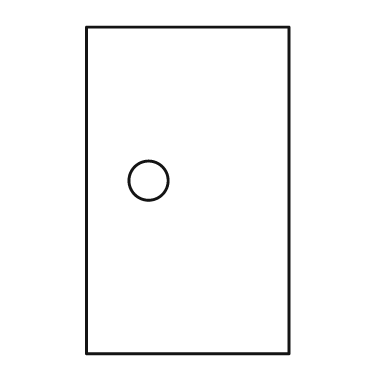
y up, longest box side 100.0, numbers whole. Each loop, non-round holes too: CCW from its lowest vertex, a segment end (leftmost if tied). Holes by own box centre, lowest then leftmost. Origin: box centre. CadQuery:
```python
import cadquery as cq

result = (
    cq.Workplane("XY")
    .moveTo(-31.0, -50.0)
    .lineTo(31.0, -50.0)
    .lineTo(31.0, 50.0)
    .lineTo(-31.0, 50.0)
    .close()
    .moveTo(-12.0, 3.0)
    .circle(6.0)
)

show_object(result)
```